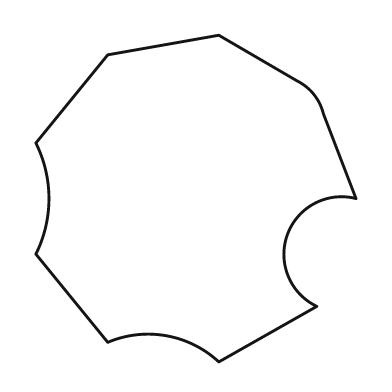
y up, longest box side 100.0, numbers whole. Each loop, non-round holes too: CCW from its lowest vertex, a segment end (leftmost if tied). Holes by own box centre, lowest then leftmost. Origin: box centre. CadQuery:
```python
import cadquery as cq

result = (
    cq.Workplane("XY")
    .moveTo(7.0, -50.0)
    .lineTo(37.0, -33.0)
    .threePointArc((28.0, -11.0), (49.0, 0.0))
    .lineTo(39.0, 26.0)
    .threePointArc((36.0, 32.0), (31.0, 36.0))
    .lineTo(7.0, 50.0)
    .lineTo(-27.0, 44.0)
    .lineTo(-49.0, 17.0)
    .threePointArc((-45.0, 0.0), (-49.0, -17.0))
    .lineTo(-27.0, -44.0)
    .threePointArc((-9.0, -42.0), (7.0, -50.0))
    .close()
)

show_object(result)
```